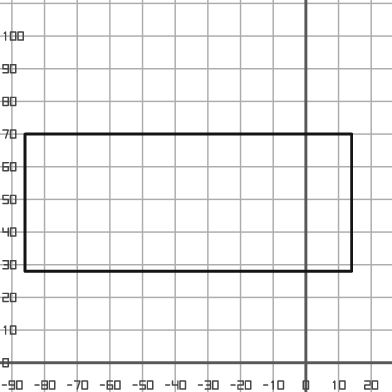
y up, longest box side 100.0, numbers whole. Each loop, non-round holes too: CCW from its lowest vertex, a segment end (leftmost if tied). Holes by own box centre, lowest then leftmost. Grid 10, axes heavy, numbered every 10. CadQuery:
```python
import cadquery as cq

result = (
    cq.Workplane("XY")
    .moveTo(-86.0, 28.0)
    .lineTo(14.0, 28.0)
    .lineTo(14.0, 70.0)
    .lineTo(-86.0, 70.0)
    .close()
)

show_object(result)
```